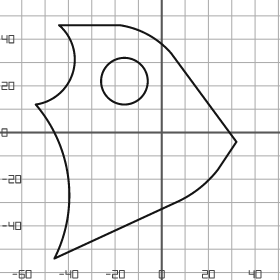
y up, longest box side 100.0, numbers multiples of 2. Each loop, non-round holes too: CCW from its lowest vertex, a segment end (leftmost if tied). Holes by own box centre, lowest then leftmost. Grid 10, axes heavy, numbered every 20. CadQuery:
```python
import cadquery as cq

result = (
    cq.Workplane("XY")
    .moveTo(-46.0, -54.0)
    .lineTo(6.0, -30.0)
    .threePointArc((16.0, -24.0), (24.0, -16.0))
    .lineTo(32.0, -4.0)
    .lineTo(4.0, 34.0)
    .threePointArc((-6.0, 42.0), (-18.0, 46.0))
    .lineTo(-44.0, 46.0)
    .threePointArc((-38.0, 26.0), (-54.0, 12.0))
    .threePointArc((-40.0, -20.0), (-46.0, -54.0))
    .close()
    .moveTo(-16.0, 22.0)
    .circle(10.0)
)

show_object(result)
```